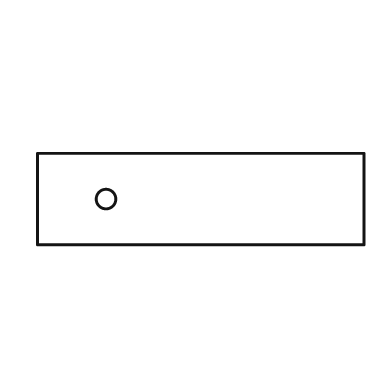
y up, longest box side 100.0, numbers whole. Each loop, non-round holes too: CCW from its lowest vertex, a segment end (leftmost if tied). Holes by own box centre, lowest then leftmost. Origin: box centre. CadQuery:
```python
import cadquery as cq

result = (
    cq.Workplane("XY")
    .moveTo(-50.0, -14.0)
    .lineTo(50.0, -14.0)
    .lineTo(50.0, 14.0)
    .lineTo(-50.0, 14.0)
    .close()
    .moveTo(-29.0, 0.0)
    .circle(3.0)
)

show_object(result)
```